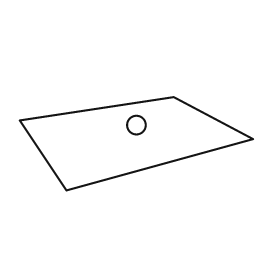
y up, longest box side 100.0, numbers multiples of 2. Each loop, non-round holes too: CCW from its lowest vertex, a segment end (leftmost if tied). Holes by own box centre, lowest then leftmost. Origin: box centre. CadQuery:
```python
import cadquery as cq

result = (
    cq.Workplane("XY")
    .moveTo(-30.0, -20.0)
    .lineTo(50.0, 2.0)
    .lineTo(16.0, 20.0)
    .lineTo(-50.0, 10.0)
    .close()
    .moveTo(0.0, 8.0)
    .circle(4.0)
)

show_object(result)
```